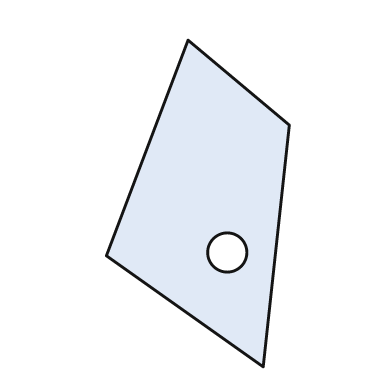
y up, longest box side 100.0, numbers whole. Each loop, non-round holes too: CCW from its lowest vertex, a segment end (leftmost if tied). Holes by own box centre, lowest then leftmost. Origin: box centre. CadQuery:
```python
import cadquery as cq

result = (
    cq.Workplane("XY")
    .moveTo(20.0, -50.0)
    .lineTo(28.0, 24.0)
    .lineTo(-3.0, 50.0)
    .lineTo(-28.0, -16.0)
    .close()
    .moveTo(9.0, -15.0)
    .circle(6.0)
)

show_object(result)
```